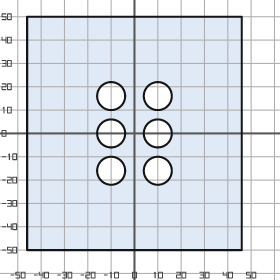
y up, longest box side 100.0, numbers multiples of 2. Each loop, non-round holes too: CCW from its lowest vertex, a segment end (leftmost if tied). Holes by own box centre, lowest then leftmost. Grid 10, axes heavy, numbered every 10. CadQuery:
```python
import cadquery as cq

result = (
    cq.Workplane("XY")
    .moveTo(-46.0, -50.0)
    .lineTo(46.0, -50.0)
    .lineTo(46.0, 50.0)
    .lineTo(-46.0, 50.0)
    .close()
    .moveTo(-10.0, -16.0)
    .circle(6.0)
    .moveTo(10.0, -16.0)
    .circle(6.0)
    .moveTo(-10.0, 0.0)
    .circle(6.0)
    .moveTo(10.0, 0.0)
    .circle(6.0)
    .moveTo(-10.0, 16.0)
    .circle(6.0)
    .moveTo(10.0, 16.0)
    .circle(6.0)
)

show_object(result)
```